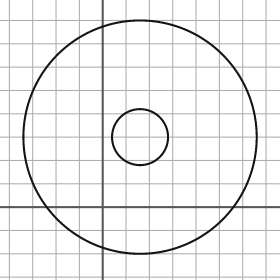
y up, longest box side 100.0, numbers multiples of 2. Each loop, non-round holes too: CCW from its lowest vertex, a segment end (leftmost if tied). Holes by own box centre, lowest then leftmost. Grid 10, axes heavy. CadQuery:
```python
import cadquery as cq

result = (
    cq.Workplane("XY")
    .moveTo(16.0, 30.0)
    .circle(50.0)
    .moveTo(16.0, 30.0)
    .circle(12.0)
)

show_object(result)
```